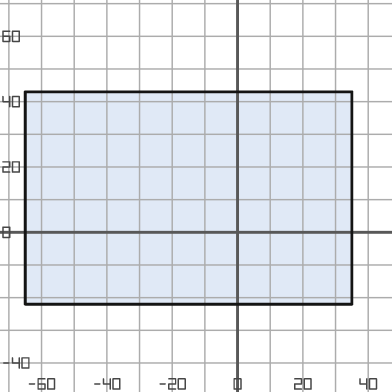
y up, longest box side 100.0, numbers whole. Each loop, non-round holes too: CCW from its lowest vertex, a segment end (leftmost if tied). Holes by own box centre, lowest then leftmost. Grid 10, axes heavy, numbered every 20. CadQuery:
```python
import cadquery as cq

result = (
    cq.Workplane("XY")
    .moveTo(-65.0, -22.0)
    .lineTo(35.0, -22.0)
    .lineTo(35.0, 43.0)
    .lineTo(-65.0, 43.0)
    .close()
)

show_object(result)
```